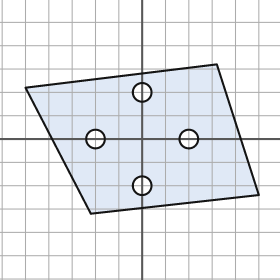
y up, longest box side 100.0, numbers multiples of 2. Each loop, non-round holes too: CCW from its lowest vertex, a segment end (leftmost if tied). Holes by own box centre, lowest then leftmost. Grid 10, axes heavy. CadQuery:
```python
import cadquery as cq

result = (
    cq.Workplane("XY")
    .moveTo(-22.0, -32.0)
    .lineTo(50.0, -24.0)
    .lineTo(32.0, 32.0)
    .lineTo(-50.0, 22.0)
    .close()
    .moveTo(0.0, -20.0)
    .circle(4.0)
    .moveTo(-20.0, 0.0)
    .circle(4.0)
    .moveTo(20.0, 0.0)
    .circle(4.0)
    .moveTo(0.0, 20.0)
    .circle(4.0)
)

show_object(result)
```